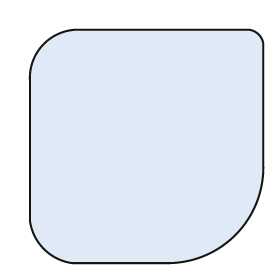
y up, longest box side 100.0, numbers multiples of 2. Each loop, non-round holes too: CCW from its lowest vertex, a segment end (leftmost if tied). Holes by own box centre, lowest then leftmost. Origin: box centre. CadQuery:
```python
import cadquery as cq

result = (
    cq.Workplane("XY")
    .moveTo(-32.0, -50.0)
    .lineTo(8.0, -50.0)
    .threePointArc((38.0, -38.0), (50.0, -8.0))
    .lineTo(50.0, 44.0)
    .threePointArc((48.0, 48.0), (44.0, 50.0))
    .lineTo(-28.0, 50.0)
    .threePointArc((-44.0, 44.0), (-50.0, 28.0))
    .lineTo(-50.0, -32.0)
    .threePointArc((-44.0, -44.0), (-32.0, -50.0))
    .close()
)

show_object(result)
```